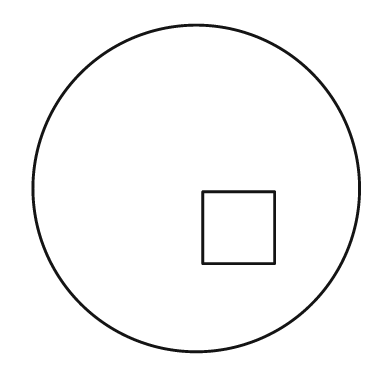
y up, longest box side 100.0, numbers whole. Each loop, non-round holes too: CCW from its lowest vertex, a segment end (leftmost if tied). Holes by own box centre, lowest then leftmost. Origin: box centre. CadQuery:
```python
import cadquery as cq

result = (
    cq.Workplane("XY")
    .moveTo(0.0, 0.0)
    .circle(50.0)
    .moveTo(2.0, -23.0)
    .lineTo(24.0, -23.0)
    .lineTo(24.0, -1.0)
    .lineTo(2.0, -1.0)
    .close()
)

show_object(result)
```